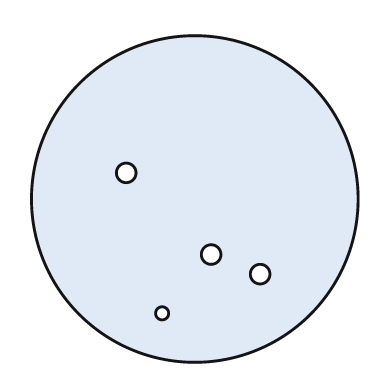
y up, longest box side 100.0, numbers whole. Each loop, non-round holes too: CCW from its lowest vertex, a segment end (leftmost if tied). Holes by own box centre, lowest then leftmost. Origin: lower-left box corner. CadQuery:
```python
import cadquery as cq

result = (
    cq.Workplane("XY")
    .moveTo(50.0, 50.0)
    .circle(50.0)
    .moveTo(40.0, 15.0)
    .circle(2.0)
    .moveTo(70.0, 27.0)
    .circle(3.0)
    .moveTo(55.0, 33.0)
    .circle(3.0)
    .moveTo(29.0, 58.0)
    .circle(3.0)
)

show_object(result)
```